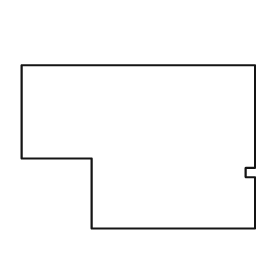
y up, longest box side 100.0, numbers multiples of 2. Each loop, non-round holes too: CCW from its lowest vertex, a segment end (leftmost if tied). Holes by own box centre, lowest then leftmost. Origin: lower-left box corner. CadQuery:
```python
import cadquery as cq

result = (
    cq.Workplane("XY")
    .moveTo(30.0, 0.0)
    .lineTo(100.0, 0.0)
    .lineTo(100.0, 22.0)
    .lineTo(96.0, 22.0)
    .lineTo(96.0, 26.0)
    .lineTo(100.0, 26.0)
    .lineTo(100.0, 70.0)
    .lineTo(0.0, 70.0)
    .lineTo(0.0, 30.0)
    .lineTo(30.0, 30.0)
    .close()
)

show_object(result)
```